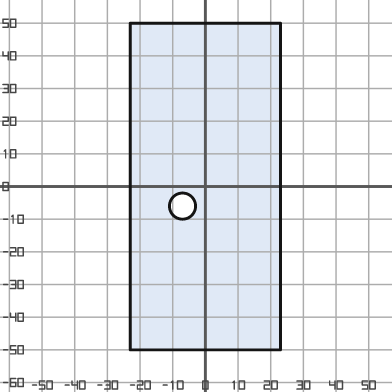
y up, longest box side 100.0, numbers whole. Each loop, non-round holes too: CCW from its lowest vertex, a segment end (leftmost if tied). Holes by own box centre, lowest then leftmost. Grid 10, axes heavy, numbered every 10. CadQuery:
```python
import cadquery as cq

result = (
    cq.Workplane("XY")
    .moveTo(-23.0, -50.0)
    .lineTo(23.0, -50.0)
    .lineTo(23.0, 50.0)
    .lineTo(-23.0, 50.0)
    .close()
    .moveTo(-7.0, -6.0)
    .circle(4.0)
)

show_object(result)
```